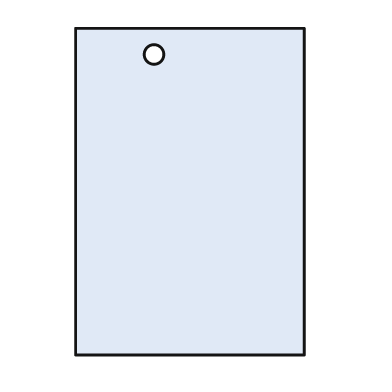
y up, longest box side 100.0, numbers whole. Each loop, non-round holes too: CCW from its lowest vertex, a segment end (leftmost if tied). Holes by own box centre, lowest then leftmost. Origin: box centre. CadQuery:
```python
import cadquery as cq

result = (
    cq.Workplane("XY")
    .moveTo(-35.0, -50.0)
    .lineTo(35.0, -50.0)
    .lineTo(35.0, 50.0)
    .lineTo(-35.0, 50.0)
    .close()
    .moveTo(-11.0, 42.0)
    .circle(3.0)
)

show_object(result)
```